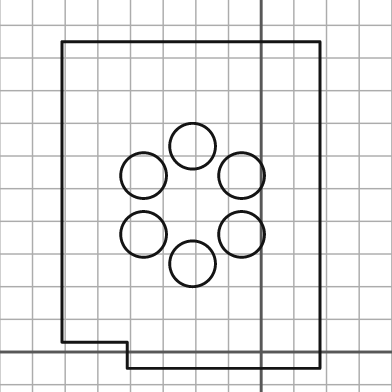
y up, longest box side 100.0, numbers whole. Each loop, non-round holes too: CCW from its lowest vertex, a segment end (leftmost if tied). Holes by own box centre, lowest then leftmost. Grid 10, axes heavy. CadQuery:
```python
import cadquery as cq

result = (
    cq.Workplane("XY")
    .moveTo(-41.0, -5.0)
    .lineTo(18.0, -5.0)
    .lineTo(18.0, 95.0)
    .lineTo(-61.0, 95.0)
    .lineTo(-61.0, 3.0)
    .lineTo(-41.0, 3.0)
    .close()
    .moveTo(-21.0, 27.0)
    .circle(7.0)
    .moveTo(-36.0, 36.0)
    .circle(7.0)
    .moveTo(-6.0, 36.0)
    .circle(7.0)
    .moveTo(-36.0, 54.0)
    .circle(7.0)
    .moveTo(-6.0, 54.0)
    .circle(7.0)
    .moveTo(-21.0, 63.0)
    .circle(7.0)
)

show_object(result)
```